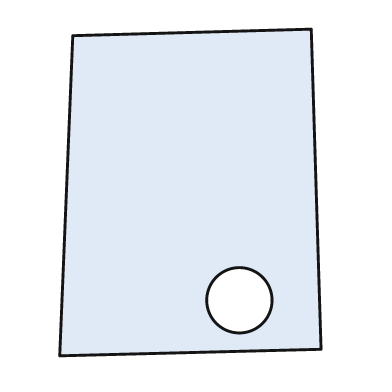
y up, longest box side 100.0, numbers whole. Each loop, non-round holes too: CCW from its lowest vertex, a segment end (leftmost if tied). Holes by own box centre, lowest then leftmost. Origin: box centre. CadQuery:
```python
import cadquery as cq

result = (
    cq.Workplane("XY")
    .moveTo(-40.0, -50.0)
    .lineTo(40.0, -48.0)
    .lineTo(37.0, 50.0)
    .lineTo(-36.0, 48.0)
    .close()
    .moveTo(15.0, -33.0)
    .circle(10.0)
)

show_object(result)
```